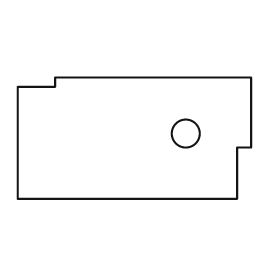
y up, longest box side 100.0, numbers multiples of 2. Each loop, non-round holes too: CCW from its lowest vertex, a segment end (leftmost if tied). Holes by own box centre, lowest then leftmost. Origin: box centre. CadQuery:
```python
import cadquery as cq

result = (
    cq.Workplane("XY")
    .moveTo(-50.0, -26.0)
    .lineTo(44.0, -26.0)
    .lineTo(44.0, -4.0)
    .lineTo(50.0, -4.0)
    .lineTo(50.0, 26.0)
    .lineTo(-34.0, 26.0)
    .lineTo(-34.0, 22.0)
    .lineTo(-50.0, 22.0)
    .close()
    .moveTo(22.0, 2.0)
    .circle(6.0)
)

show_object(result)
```